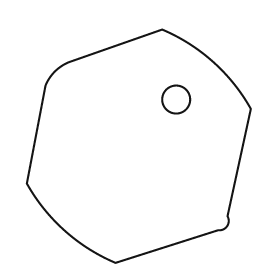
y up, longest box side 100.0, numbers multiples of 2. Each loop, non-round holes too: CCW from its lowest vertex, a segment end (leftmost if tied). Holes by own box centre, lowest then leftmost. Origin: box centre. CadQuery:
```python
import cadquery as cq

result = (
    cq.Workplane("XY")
    .moveTo(-10.0, -50.0)
    .lineTo(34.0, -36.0)
    .threePointArc((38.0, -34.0), (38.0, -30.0))
    .lineTo(48.0, 16.0)
    .threePointArc((32.0, 36.0), (10.0, 50.0))
    .lineTo(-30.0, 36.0)
    .threePointArc((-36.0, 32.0), (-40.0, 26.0))
    .lineTo(-48.0, -16.0)
    .threePointArc((-32.0, -36.0), (-10.0, -50.0))
    .close()
    .moveTo(16.0, 20.0)
    .circle(6.0)
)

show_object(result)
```